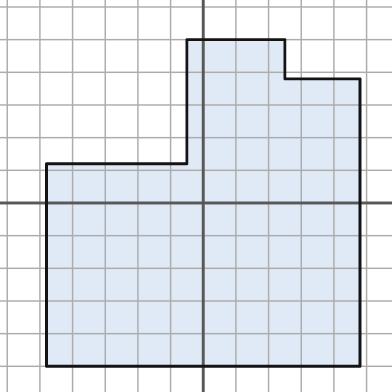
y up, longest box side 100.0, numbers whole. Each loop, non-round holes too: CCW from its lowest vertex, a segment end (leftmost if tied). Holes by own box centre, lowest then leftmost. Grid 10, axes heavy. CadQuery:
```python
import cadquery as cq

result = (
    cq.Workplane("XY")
    .moveTo(-48.0, -50.0)
    .lineTo(48.0, -50.0)
    .lineTo(48.0, 38.0)
    .lineTo(25.0, 38.0)
    .lineTo(25.0, 50.0)
    .lineTo(-5.0, 50.0)
    .lineTo(-5.0, 12.0)
    .lineTo(-48.0, 12.0)
    .close()
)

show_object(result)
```